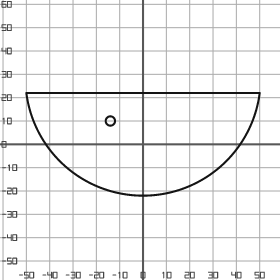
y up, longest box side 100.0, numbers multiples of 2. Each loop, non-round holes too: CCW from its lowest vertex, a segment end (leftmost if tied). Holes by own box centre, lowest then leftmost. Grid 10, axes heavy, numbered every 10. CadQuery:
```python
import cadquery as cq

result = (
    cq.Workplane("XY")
    .moveTo(-50.0, 22.0)
    .threePointArc((0.0, -22.0), (50.0, 22.0))
    .close()
    .moveTo(-14.0, 10.0)
    .circle(2.0)
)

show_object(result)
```